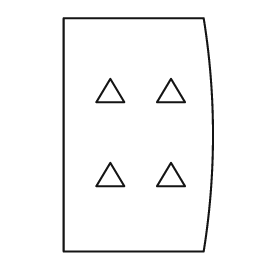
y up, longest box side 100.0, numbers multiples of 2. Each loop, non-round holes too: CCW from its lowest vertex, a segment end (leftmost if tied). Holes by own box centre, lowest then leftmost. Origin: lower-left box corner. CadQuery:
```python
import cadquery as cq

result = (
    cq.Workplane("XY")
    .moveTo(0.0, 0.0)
    .lineTo(60.0, 0.0)
    .threePointArc((64.0, 50.0), (60.0, 100.0))
    .lineTo(0.0, 100.0)
    .close()
    .moveTo(14.0, 28.0)
    .lineTo(26.0, 28.0)
    .lineTo(20.0, 38.0)
    .close()
    .moveTo(40.0, 28.0)
    .lineTo(52.0, 28.0)
    .lineTo(46.0, 38.0)
    .close()
    .moveTo(14.0, 64.0)
    .lineTo(26.0, 64.0)
    .lineTo(20.0, 74.0)
    .close()
    .moveTo(40.0, 64.0)
    .lineTo(52.0, 64.0)
    .lineTo(46.0, 74.0)
    .close()
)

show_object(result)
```